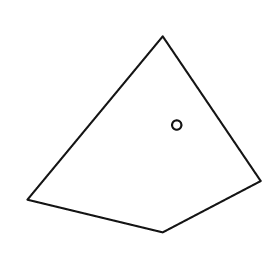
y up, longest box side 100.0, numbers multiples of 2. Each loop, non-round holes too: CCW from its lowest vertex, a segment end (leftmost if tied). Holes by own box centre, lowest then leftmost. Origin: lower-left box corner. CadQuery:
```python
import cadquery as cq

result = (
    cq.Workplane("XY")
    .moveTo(58.0, 0.0)
    .lineTo(100.0, 22.0)
    .lineTo(58.0, 84.0)
    .lineTo(0.0, 14.0)
    .close()
    .moveTo(64.0, 46.0)
    .circle(2.0)
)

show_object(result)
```